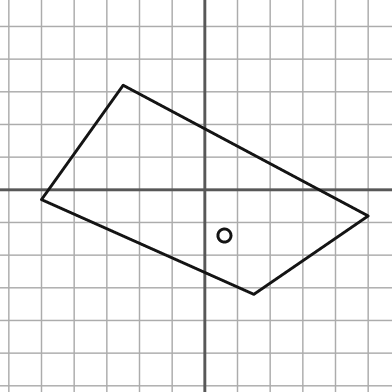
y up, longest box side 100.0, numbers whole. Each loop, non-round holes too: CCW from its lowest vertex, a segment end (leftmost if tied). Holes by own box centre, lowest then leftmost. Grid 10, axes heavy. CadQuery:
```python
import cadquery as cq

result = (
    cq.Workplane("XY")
    .moveTo(15.0, -32.0)
    .lineTo(50.0, -8.0)
    .lineTo(-25.0, 32.0)
    .lineTo(-50.0, -3.0)
    .close()
    .moveTo(6.0, -14.0)
    .circle(2.0)
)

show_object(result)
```